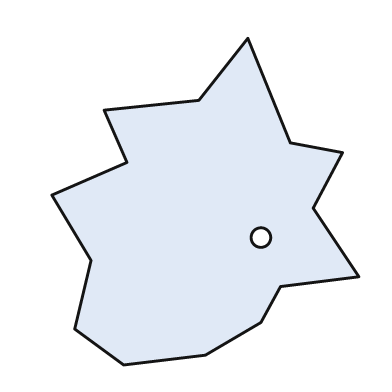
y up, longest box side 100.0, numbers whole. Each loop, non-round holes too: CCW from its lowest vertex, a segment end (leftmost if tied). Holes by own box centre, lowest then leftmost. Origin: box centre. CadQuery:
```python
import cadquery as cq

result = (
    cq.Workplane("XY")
    .moveTo(-25.0, -50.0)
    .lineTo(0.0, -47.0)
    .lineTo(17.0, -37.0)
    .lineTo(23.0, -26.0)
    .lineTo(47.0, -23.0)
    .lineTo(33.0, -2.0)
    .lineTo(42.0, 15.0)
    .lineTo(26.0, 18.0)
    .lineTo(13.0, 50.0)
    .lineTo(-2.0, 31.0)
    .lineTo(-31.0, 28.0)
    .lineTo(-24.0, 12.0)
    .lineTo(-47.0, 2.0)
    .lineTo(-35.0, -18.0)
    .lineTo(-40.0, -39.0)
    .close()
    .moveTo(17.0, -11.0)
    .circle(3.0)
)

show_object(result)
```